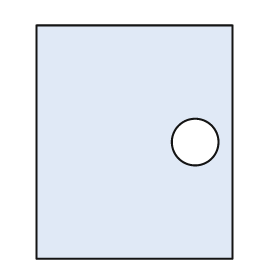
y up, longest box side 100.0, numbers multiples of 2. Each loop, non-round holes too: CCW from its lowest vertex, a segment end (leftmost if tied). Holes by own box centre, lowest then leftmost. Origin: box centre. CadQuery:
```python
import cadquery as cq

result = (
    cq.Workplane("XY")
    .moveTo(-42.0, -50.0)
    .lineTo(42.0, -50.0)
    .lineTo(42.0, 50.0)
    .lineTo(-42.0, 50.0)
    .close()
    .moveTo(26.0, 0.0)
    .circle(10.0)
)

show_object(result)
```